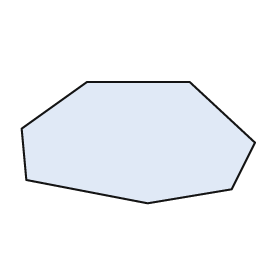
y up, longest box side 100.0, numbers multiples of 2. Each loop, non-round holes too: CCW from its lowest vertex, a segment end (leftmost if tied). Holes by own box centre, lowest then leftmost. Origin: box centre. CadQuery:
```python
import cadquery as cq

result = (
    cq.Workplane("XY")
    .moveTo(4.0, -26.0)
    .lineTo(40.0, -20.0)
    .lineTo(50.0, 0.0)
    .lineTo(22.0, 26.0)
    .lineTo(-22.0, 26.0)
    .lineTo(-50.0, 6.0)
    .lineTo(-48.0, -16.0)
    .close()
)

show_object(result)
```